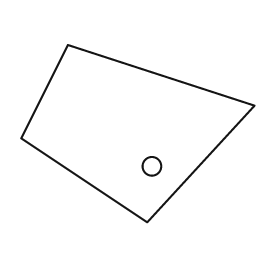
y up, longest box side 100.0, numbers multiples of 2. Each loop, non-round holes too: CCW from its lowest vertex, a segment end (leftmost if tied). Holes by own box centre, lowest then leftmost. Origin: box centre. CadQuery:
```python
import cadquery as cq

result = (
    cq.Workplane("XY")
    .moveTo(4.0, -38.0)
    .lineTo(50.0, 12.0)
    .lineTo(-30.0, 38.0)
    .lineTo(-50.0, -2.0)
    .close()
    .moveTo(6.0, -14.0)
    .circle(4.0)
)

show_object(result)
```